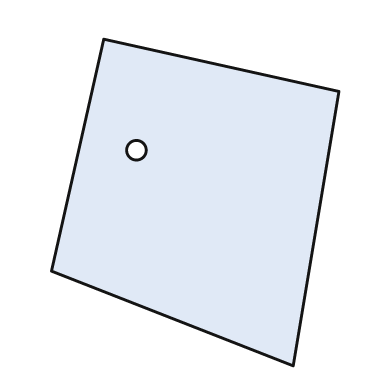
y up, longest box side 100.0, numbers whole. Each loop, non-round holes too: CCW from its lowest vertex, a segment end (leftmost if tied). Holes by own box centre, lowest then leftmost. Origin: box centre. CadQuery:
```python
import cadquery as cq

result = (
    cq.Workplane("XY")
    .moveTo(30.0, -50.0)
    .lineTo(44.0, 34.0)
    .lineTo(-28.0, 50.0)
    .lineTo(-44.0, -21.0)
    .close()
    .moveTo(-18.0, 16.0)
    .circle(3.0)
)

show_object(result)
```